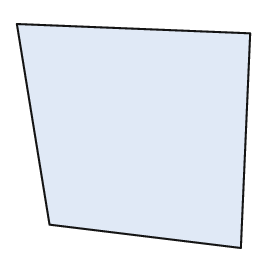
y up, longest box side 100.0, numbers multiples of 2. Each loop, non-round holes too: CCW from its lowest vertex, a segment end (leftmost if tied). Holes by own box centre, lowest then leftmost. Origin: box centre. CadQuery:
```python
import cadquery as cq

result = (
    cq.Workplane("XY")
    .moveTo(46.0, -48.0)
    .lineTo(50.0, 44.0)
    .lineTo(-50.0, 48.0)
    .lineTo(-36.0, -38.0)
    .close()
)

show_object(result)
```